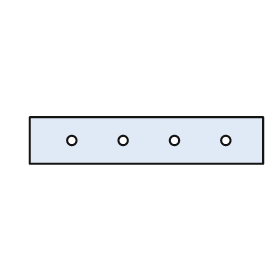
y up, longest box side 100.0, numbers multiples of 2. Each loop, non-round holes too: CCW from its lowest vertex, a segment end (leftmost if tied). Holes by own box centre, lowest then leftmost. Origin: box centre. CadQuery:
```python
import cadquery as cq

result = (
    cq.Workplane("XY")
    .moveTo(-50.0, -10.0)
    .lineTo(50.0, -10.0)
    .lineTo(50.0, 10.0)
    .lineTo(-50.0, 10.0)
    .close()
    .moveTo(-32.0, 0.0)
    .circle(2.0)
    .moveTo(-10.0, 0.0)
    .circle(2.0)
    .moveTo(12.0, 0.0)
    .circle(2.0)
    .moveTo(34.0, 0.0)
    .circle(2.0)
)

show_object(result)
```